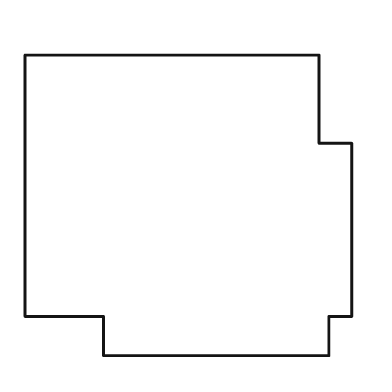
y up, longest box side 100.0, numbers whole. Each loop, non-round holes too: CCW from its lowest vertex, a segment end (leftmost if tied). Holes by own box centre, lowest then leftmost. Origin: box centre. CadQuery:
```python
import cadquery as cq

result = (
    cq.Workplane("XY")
    .moveTo(-26.0, -46.0)
    .lineTo(43.0, -46.0)
    .lineTo(43.0, -34.0)
    .lineTo(50.0, -34.0)
    .lineTo(50.0, 19.0)
    .lineTo(40.0, 19.0)
    .lineTo(40.0, 46.0)
    .lineTo(-50.0, 46.0)
    .lineTo(-50.0, -34.0)
    .lineTo(-26.0, -34.0)
    .close()
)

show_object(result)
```